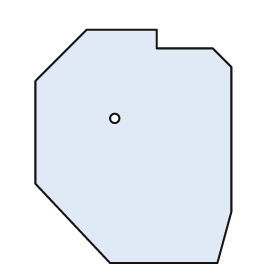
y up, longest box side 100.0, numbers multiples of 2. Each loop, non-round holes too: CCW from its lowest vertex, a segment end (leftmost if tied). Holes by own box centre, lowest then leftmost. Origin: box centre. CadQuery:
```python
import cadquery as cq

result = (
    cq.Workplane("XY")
    .moveTo(-10.0, -50.0)
    .lineTo(36.0, -50.0)
    .lineTo(42.0, -28.0)
    .lineTo(42.0, 34.0)
    .lineTo(34.0, 42.0)
    .lineTo(10.0, 42.0)
    .lineTo(10.0, 50.0)
    .lineTo(-20.0, 50.0)
    .lineTo(-42.0, 28.0)
    .lineTo(-42.0, -16.0)
    .close()
    .moveTo(-8.0, 12.0)
    .circle(2.0)
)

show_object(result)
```